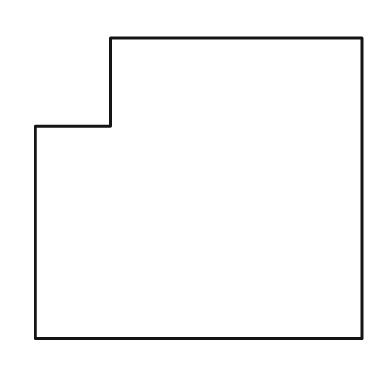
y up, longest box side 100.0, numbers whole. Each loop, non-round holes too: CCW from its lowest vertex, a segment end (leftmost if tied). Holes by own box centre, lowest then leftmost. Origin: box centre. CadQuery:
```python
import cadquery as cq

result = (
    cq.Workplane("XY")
    .moveTo(-50.0, -46.0)
    .lineTo(50.0, -46.0)
    .lineTo(50.0, 46.0)
    .lineTo(-27.0, 46.0)
    .lineTo(-27.0, 19.0)
    .lineTo(-50.0, 19.0)
    .close()
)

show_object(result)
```